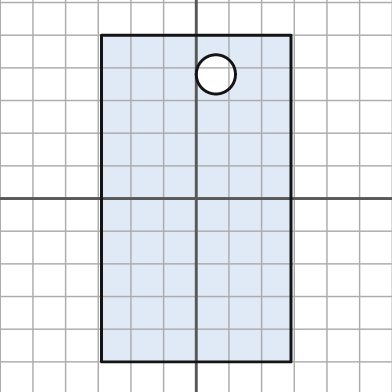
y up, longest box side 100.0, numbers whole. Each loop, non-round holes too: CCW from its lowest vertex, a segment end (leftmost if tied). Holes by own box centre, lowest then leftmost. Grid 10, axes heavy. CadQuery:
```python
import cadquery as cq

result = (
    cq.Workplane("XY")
    .moveTo(-29.0, -50.0)
    .lineTo(29.0, -50.0)
    .lineTo(29.0, 50.0)
    .lineTo(-29.0, 50.0)
    .close()
    .moveTo(6.0, 38.0)
    .circle(6.0)
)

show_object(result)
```